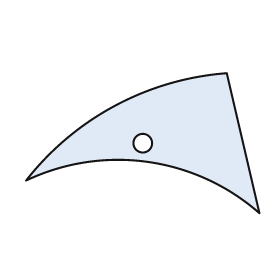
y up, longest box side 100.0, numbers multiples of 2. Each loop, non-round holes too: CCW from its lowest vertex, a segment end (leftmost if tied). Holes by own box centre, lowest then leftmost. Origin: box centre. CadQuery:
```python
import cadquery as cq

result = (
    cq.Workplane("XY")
    .moveTo(50.0, -30.0)
    .lineTo(36.0, 30.0)
    .threePointArc((-12.0, 16.0), (-50.0, -16.0))
    .threePointArc((2.0, -8.0), (50.0, -30.0))
    .close()
    .moveTo(0.0, 0.0)
    .circle(4.0)
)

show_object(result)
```